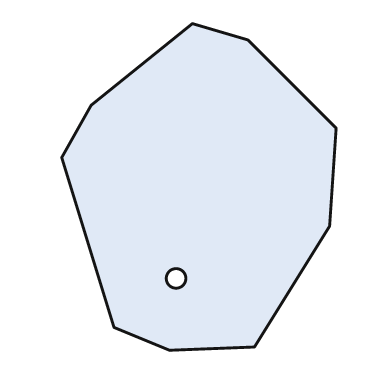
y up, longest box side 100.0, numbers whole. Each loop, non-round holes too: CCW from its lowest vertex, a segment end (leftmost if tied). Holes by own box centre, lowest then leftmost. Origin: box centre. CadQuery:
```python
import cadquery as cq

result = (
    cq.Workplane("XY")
    .moveTo(-9.0, -50.0)
    .lineTo(17.0, -49.0)
    .lineTo(40.0, -12.0)
    .lineTo(42.0, 18.0)
    .lineTo(15.0, 45.0)
    .lineTo(-2.0, 50.0)
    .lineTo(-33.0, 25.0)
    .lineTo(-42.0, 9.0)
    .lineTo(-26.0, -43.0)
    .close()
    .moveTo(-7.0, -28.0)
    .circle(3.0)
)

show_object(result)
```